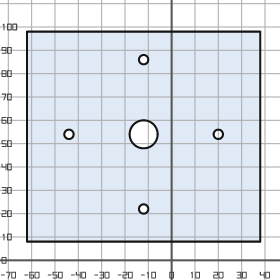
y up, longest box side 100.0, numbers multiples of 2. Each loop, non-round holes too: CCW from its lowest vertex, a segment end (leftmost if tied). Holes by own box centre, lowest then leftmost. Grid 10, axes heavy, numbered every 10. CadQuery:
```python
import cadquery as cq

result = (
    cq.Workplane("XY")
    .moveTo(-62.0, 8.0)
    .lineTo(38.0, 8.0)
    .lineTo(38.0, 98.0)
    .lineTo(-62.0, 98.0)
    .close()
    .moveTo(-12.0, 22.0)
    .circle(2.0)
    .moveTo(-44.0, 54.0)
    .circle(2.0)
    .moveTo(-12.0, 54.0)
    .circle(6.0)
    .moveTo(20.0, 54.0)
    .circle(2.0)
    .moveTo(-12.0, 86.0)
    .circle(2.0)
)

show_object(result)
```